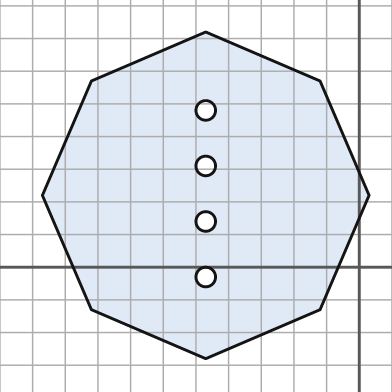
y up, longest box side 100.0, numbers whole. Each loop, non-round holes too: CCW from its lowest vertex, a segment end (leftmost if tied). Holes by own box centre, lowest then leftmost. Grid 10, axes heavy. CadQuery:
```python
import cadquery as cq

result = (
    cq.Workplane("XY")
    .moveTo(-47.0, -28.0)
    .lineTo(-12.0, -13.0)
    .lineTo(3.0, 22.0)
    .lineTo(-12.0, 57.0)
    .lineTo(-47.0, 72.0)
    .lineTo(-82.0, 57.0)
    .lineTo(-97.0, 22.0)
    .lineTo(-82.0, -13.0)
    .close()
    .moveTo(-47.0, -3.0)
    .circle(3.0)
    .moveTo(-47.0, 14.0)
    .circle(3.0)
    .moveTo(-47.0, 31.0)
    .circle(3.0)
    .moveTo(-47.0, 48.0)
    .circle(3.0)
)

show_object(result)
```